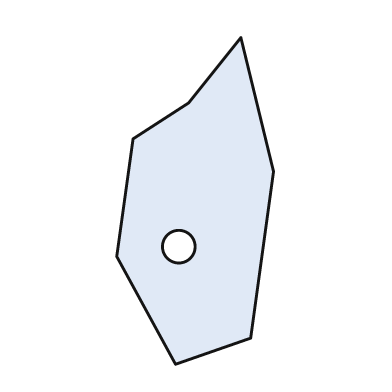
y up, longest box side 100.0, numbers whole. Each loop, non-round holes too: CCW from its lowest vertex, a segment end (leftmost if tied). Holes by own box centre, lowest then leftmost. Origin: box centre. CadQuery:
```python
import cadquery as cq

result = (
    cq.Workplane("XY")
    .moveTo(-6.0, -50.0)
    .lineTo(17.0, -42.0)
    .lineTo(24.0, 9.0)
    .lineTo(14.0, 50.0)
    .lineTo(-2.0, 30.0)
    .lineTo(-19.0, 19.0)
    .lineTo(-24.0, -17.0)
    .close()
    .moveTo(-5.0, -14.0)
    .circle(5.0)
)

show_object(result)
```